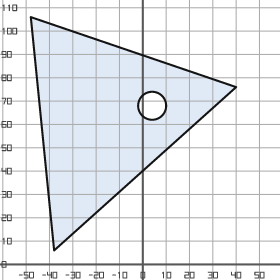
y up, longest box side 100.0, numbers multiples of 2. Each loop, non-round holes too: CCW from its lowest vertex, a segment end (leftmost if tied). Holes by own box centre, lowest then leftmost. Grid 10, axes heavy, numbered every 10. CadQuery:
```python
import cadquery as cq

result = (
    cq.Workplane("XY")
    .moveTo(-38.0, 6.0)
    .lineTo(40.0, 76.0)
    .lineTo(-48.0, 106.0)
    .close()
    .moveTo(4.0, 68.0)
    .circle(6.0)
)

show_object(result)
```